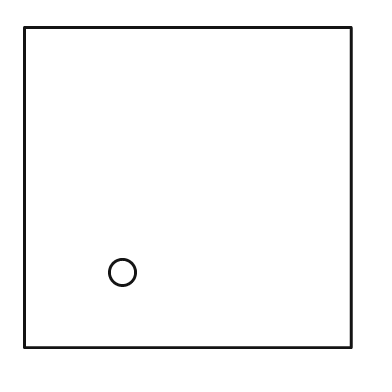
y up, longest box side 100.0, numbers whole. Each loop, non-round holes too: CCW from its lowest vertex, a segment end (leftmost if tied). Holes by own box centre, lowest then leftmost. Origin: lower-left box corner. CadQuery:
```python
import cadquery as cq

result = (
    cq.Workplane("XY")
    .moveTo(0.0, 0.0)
    .lineTo(100.0, 0.0)
    .lineTo(100.0, 98.0)
    .lineTo(0.0, 98.0)
    .close()
    .moveTo(30.0, 23.0)
    .circle(4.0)
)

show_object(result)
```